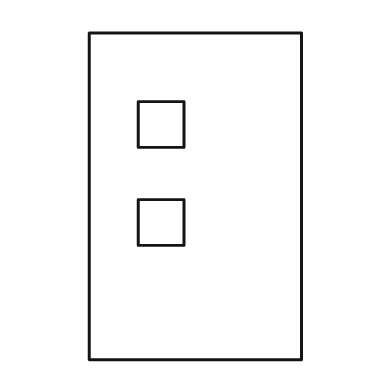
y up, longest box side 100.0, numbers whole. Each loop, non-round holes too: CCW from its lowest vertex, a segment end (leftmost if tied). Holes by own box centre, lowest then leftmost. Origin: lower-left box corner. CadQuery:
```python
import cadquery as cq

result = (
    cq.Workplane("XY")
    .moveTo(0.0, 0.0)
    .lineTo(65.0, 0.0)
    .lineTo(65.0, 100.0)
    .lineTo(0.0, 100.0)
    .close()
    .moveTo(15.0, 35.0)
    .lineTo(29.0, 35.0)
    .lineTo(29.0, 49.0)
    .lineTo(15.0, 49.0)
    .close()
    .moveTo(15.0, 65.0)
    .lineTo(29.0, 65.0)
    .lineTo(29.0, 79.0)
    .lineTo(15.0, 79.0)
    .close()
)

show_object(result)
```